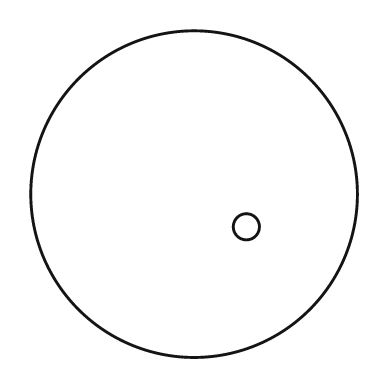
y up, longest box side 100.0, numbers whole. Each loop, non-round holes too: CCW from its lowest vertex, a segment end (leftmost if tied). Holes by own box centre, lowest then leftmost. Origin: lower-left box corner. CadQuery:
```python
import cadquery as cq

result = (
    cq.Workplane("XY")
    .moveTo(50.0, 50.0)
    .circle(50.0)
    .moveTo(66.0, 40.0)
    .circle(4.0)
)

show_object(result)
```